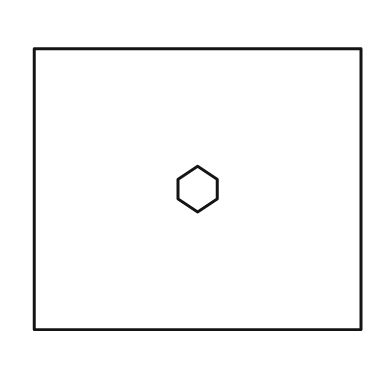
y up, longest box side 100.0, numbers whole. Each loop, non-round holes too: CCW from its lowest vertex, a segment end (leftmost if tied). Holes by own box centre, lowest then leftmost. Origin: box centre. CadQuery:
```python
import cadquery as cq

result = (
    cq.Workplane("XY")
    .moveTo(-50.0, -43.0)
    .lineTo(50.0, -43.0)
    .lineTo(50.0, 43.0)
    .lineTo(-50.0, 43.0)
    .close()
    .moveTo(0.0, -7.0)
    .lineTo(6.0, -3.0)
    .lineTo(6.0, 3.0)
    .lineTo(0.0, 7.0)
    .lineTo(-6.0, 3.0)
    .lineTo(-6.0, -3.0)
    .close()
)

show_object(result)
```